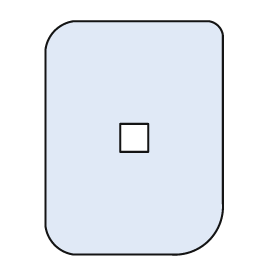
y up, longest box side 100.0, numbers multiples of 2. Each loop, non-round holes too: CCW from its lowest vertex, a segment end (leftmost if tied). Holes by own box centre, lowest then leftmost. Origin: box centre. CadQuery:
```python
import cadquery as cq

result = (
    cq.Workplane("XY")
    .moveTo(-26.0, -50.0)
    .lineTo(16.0, -50.0)
    .threePointArc((32.0, -44.0), (38.0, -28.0))
    .lineTo(38.0, 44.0)
    .threePointArc((36.0, 48.0), (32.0, 50.0))
    .lineTo(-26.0, 50.0)
    .threePointArc((-34.0, 46.0), (-38.0, 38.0))
    .lineTo(-38.0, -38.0)
    .threePointArc((-34.0, -46.0), (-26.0, -50.0))
    .close()
    .moveTo(-6.0, -6.0)
    .lineTo(6.0, -6.0)
    .lineTo(6.0, 6.0)
    .lineTo(-6.0, 6.0)
    .close()
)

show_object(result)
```